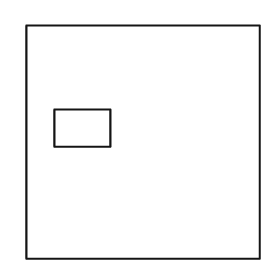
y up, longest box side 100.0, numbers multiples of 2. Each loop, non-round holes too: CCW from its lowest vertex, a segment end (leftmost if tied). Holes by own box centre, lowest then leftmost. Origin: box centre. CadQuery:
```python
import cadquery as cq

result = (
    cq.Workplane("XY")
    .moveTo(-50.0, -50.0)
    .lineTo(50.0, -50.0)
    .lineTo(50.0, 50.0)
    .lineTo(-50.0, 50.0)
    .close()
    .moveTo(-38.0, -2.0)
    .lineTo(-14.0, -2.0)
    .lineTo(-14.0, 14.0)
    .lineTo(-38.0, 14.0)
    .close()
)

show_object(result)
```